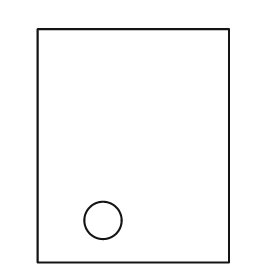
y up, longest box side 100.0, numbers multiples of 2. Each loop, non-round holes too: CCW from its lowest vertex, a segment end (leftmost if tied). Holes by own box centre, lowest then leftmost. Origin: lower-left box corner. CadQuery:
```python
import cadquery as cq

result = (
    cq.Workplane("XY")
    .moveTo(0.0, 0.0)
    .lineTo(82.0, 0.0)
    .lineTo(82.0, 100.0)
    .lineTo(0.0, 100.0)
    .close()
    .moveTo(28.0, 18.0)
    .circle(8.0)
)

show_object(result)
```